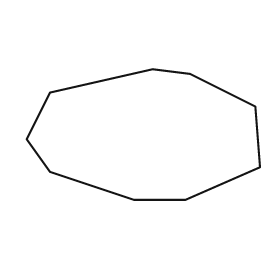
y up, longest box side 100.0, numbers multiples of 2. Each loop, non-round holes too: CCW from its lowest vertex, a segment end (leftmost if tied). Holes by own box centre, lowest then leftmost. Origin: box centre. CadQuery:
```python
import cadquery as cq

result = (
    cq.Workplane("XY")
    .moveTo(-4.0, -28.0)
    .lineTo(18.0, -28.0)
    .lineTo(50.0, -14.0)
    .lineTo(48.0, 12.0)
    .lineTo(20.0, 26.0)
    .lineTo(4.0, 28.0)
    .lineTo(-40.0, 18.0)
    .lineTo(-50.0, -2.0)
    .lineTo(-40.0, -16.0)
    .close()
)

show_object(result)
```